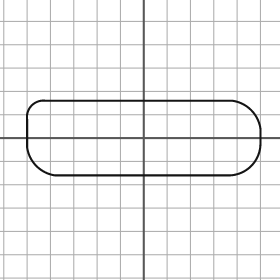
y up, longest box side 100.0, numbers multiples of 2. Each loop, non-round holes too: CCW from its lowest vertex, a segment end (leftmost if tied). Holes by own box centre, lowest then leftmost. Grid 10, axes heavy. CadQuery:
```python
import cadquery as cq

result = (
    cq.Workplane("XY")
    .moveTo(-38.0, -16.0)
    .lineTo(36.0, -16.0)
    .threePointArc((46.0, -12.0), (50.0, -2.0))
    .lineTo(50.0, 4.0)
    .threePointArc((46.0, 12.0), (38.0, 16.0))
    .lineTo(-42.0, 16.0)
    .threePointArc((-48.0, 14.0), (-50.0, 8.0))
    .lineTo(-50.0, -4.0)
    .threePointArc((-46.0, -12.0), (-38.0, -16.0))
    .close()
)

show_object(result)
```